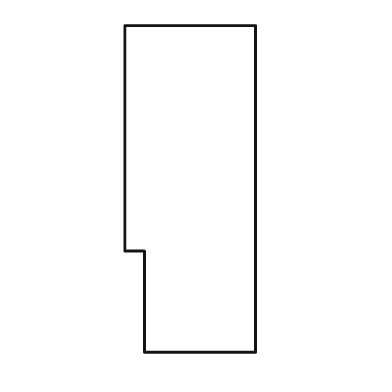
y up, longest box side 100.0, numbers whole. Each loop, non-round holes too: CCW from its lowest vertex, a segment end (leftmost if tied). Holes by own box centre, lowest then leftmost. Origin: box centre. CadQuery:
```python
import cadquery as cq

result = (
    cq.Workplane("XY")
    .moveTo(-14.0, -50.0)
    .lineTo(20.0, -50.0)
    .lineTo(20.0, 50.0)
    .lineTo(-20.0, 50.0)
    .lineTo(-20.0, -19.0)
    .lineTo(-14.0, -19.0)
    .close()
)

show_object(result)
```